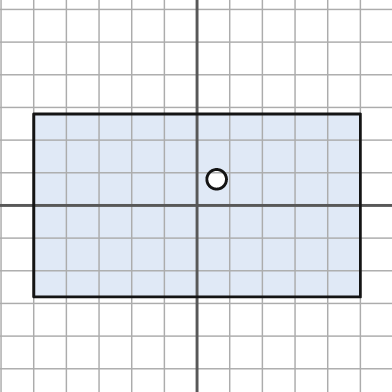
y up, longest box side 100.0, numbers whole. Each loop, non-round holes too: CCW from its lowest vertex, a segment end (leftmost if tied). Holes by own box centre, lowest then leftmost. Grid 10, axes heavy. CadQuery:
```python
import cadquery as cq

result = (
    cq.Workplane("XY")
    .moveTo(-50.0, -28.0)
    .lineTo(50.0, -28.0)
    .lineTo(50.0, 28.0)
    .lineTo(-50.0, 28.0)
    .close()
    .moveTo(6.0, 8.0)
    .circle(3.0)
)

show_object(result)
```